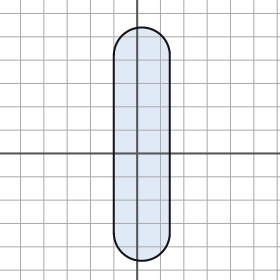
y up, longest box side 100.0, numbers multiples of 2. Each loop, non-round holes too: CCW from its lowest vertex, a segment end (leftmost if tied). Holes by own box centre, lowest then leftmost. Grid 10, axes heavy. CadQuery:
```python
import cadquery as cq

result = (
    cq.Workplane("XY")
    .moveTo(-10.0, -34.0)
    .threePointArc((2.0, -46.0), (14.0, -34.0))
    .lineTo(14.0, 42.0)
    .threePointArc((2.0, 54.0), (-10.0, 42.0))
    .close()
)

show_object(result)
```